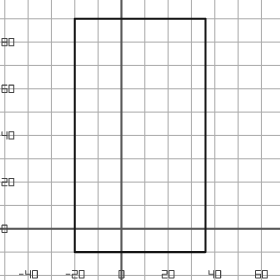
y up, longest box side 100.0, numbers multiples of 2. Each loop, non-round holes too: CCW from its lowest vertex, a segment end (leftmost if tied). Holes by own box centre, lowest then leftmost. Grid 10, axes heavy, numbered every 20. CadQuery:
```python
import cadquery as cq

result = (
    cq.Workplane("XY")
    .moveTo(-20.0, -10.0)
    .lineTo(36.0, -10.0)
    .lineTo(36.0, 90.0)
    .lineTo(-20.0, 90.0)
    .close()
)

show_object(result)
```